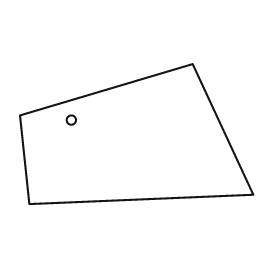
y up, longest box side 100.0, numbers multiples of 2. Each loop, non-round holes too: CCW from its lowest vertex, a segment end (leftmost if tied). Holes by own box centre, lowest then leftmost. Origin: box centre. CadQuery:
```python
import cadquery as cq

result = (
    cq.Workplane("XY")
    .moveTo(-46.0, -30.0)
    .lineTo(50.0, -26.0)
    .lineTo(24.0, 30.0)
    .lineTo(-50.0, 8.0)
    .close()
    .moveTo(-28.0, 6.0)
    .circle(2.0)
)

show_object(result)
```